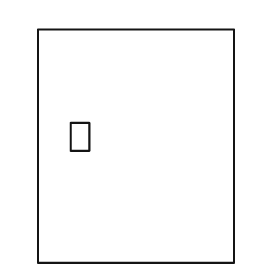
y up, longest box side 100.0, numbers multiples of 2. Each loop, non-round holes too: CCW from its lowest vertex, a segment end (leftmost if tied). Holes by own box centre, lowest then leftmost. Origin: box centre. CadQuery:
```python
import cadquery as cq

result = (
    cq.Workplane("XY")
    .moveTo(-42.0, -50.0)
    .lineTo(42.0, -50.0)
    .lineTo(42.0, 50.0)
    .lineTo(-42.0, 50.0)
    .close()
    .moveTo(-28.0, -2.0)
    .lineTo(-20.0, -2.0)
    .lineTo(-20.0, 10.0)
    .lineTo(-28.0, 10.0)
    .close()
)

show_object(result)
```